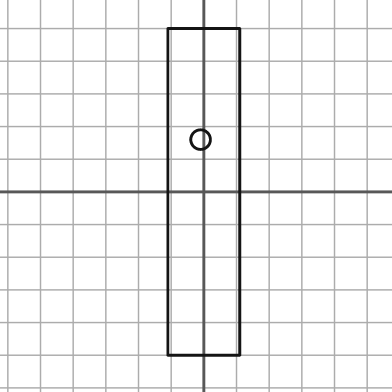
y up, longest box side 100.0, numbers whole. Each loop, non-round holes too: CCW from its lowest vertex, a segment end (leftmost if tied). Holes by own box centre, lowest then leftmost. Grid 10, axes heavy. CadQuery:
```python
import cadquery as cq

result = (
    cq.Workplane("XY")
    .moveTo(-11.0, -50.0)
    .lineTo(11.0, -50.0)
    .lineTo(11.0, 50.0)
    .lineTo(-11.0, 50.0)
    .close()
    .moveTo(-1.0, 16.0)
    .circle(3.0)
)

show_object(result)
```